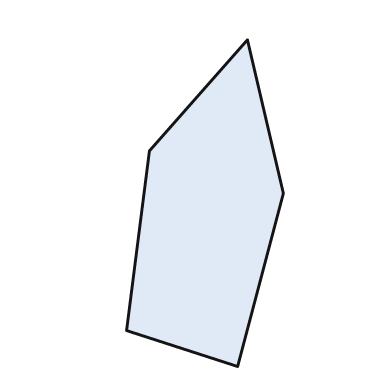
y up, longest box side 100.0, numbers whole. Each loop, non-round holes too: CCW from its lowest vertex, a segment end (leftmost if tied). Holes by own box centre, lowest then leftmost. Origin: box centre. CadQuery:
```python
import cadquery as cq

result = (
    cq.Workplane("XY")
    .moveTo(10.0, -50.0)
    .lineTo(24.0, 3.0)
    .lineTo(13.0, 50.0)
    .lineTo(-17.0, 16.0)
    .lineTo(-24.0, -39.0)
    .close()
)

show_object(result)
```